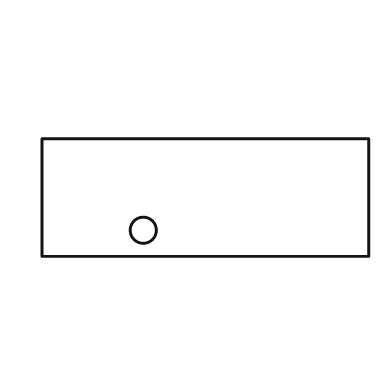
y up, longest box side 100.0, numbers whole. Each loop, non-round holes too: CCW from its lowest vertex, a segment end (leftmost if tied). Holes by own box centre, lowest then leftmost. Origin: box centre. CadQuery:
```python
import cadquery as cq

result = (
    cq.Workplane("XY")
    .moveTo(-50.0, -18.0)
    .lineTo(50.0, -18.0)
    .lineTo(50.0, 18.0)
    .lineTo(-50.0, 18.0)
    .close()
    .moveTo(-19.0, -10.0)
    .circle(4.0)
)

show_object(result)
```